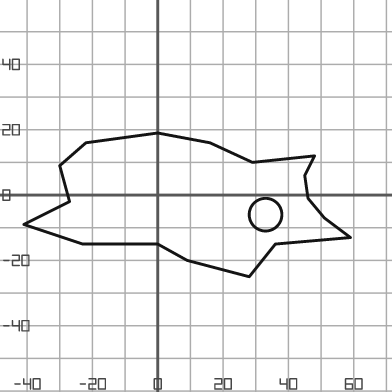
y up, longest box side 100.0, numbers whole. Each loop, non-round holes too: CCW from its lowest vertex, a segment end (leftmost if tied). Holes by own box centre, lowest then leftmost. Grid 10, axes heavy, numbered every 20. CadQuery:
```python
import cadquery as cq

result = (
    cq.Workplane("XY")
    .moveTo(28.0, -25.0)
    .lineTo(36.0, -15.0)
    .lineTo(59.0, -13.0)
    .lineTo(51.0, -7.0)
    .lineTo(46.0, -1.0)
    .lineTo(45.0, 6.0)
    .lineTo(48.0, 12.0)
    .lineTo(29.0, 10.0)
    .lineTo(16.0, 16.0)
    .lineTo(0.0, 19.0)
    .lineTo(-22.0, 16.0)
    .lineTo(-30.0, 9.0)
    .lineTo(-27.0, -2.0)
    .lineTo(-41.0, -9.0)
    .lineTo(-23.0, -15.0)
    .lineTo(0.0, -15.0)
    .lineTo(9.0, -20.0)
    .close()
    .moveTo(33.0, -6.0)
    .circle(5.0)
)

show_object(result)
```